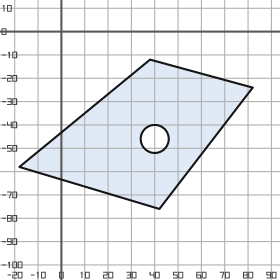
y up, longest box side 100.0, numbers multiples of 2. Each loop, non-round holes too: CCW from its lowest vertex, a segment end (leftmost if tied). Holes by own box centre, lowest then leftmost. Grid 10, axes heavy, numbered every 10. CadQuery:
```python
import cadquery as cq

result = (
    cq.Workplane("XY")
    .moveTo(42.0, -76.0)
    .lineTo(82.0, -24.0)
    .lineTo(38.0, -12.0)
    .lineTo(-18.0, -58.0)
    .close()
    .moveTo(40.0, -46.0)
    .circle(6.0)
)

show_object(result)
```